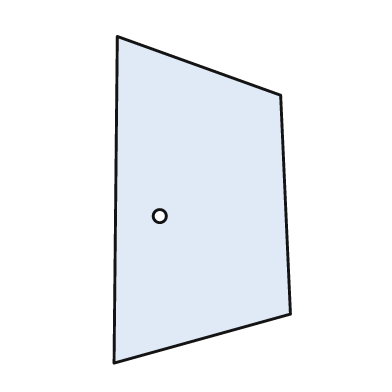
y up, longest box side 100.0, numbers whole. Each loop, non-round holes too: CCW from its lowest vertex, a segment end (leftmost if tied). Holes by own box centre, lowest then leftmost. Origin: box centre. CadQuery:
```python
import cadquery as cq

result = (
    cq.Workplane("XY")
    .moveTo(-27.0, -50.0)
    .lineTo(27.0, -35.0)
    .lineTo(24.0, 32.0)
    .lineTo(-26.0, 50.0)
    .close()
    .moveTo(-13.0, -5.0)
    .circle(2.0)
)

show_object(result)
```